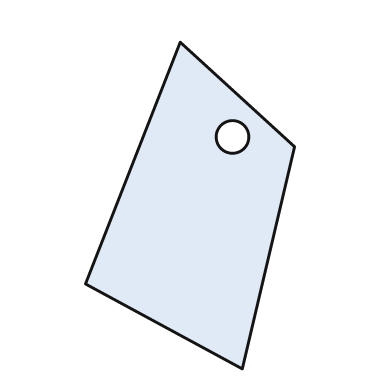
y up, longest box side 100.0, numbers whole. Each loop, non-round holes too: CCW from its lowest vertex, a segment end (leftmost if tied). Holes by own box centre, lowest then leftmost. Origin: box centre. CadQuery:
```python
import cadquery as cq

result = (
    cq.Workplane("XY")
    .moveTo(16.0, -50.0)
    .lineTo(32.0, 18.0)
    .lineTo(-3.0, 50.0)
    .lineTo(-32.0, -24.0)
    .close()
    .moveTo(13.0, 21.0)
    .circle(5.0)
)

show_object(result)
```